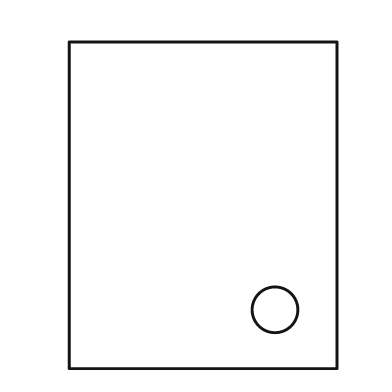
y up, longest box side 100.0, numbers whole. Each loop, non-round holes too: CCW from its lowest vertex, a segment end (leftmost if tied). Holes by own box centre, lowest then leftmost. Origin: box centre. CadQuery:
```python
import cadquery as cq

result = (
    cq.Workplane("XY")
    .moveTo(-41.0, -50.0)
    .lineTo(41.0, -50.0)
    .lineTo(41.0, 50.0)
    .lineTo(-41.0, 50.0)
    .close()
    .moveTo(22.0, -32.0)
    .circle(7.0)
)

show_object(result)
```